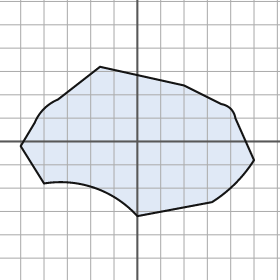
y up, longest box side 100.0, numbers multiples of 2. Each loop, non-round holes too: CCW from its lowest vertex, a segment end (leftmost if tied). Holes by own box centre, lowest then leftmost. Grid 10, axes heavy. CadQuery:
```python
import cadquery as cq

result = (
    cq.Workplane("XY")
    .moveTo(0.0, -32.0)
    .lineTo(32.0, -26.0)
    .threePointArc((42.0, -18.0), (50.0, -8.0))
    .lineTo(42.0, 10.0)
    .threePointArc((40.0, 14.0), (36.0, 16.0))
    .lineTo(20.0, 24.0)
    .lineTo(-16.0, 32.0)
    .lineTo(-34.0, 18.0)
    .threePointArc((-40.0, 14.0), (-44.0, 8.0))
    .lineTo(-50.0, -2.0)
    .lineTo(-40.0, -18.0)
    .threePointArc((-18.0, -20.0), (0.0, -32.0))
    .close()
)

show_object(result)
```